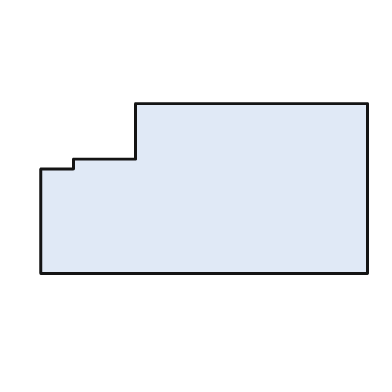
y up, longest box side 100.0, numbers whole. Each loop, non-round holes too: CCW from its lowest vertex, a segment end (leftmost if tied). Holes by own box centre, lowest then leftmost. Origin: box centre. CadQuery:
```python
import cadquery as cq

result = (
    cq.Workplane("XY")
    .moveTo(-50.0, -26.0)
    .lineTo(50.0, -26.0)
    .lineTo(50.0, 26.0)
    .lineTo(-21.0, 26.0)
    .lineTo(-21.0, 9.0)
    .lineTo(-40.0, 9.0)
    .lineTo(-40.0, 6.0)
    .lineTo(-50.0, 6.0)
    .close()
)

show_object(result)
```